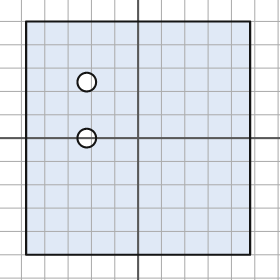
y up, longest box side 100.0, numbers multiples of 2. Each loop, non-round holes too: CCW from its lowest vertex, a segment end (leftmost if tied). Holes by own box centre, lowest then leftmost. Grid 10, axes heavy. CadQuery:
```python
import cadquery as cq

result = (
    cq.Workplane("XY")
    .moveTo(-48.0, -50.0)
    .lineTo(48.0, -50.0)
    .lineTo(48.0, 50.0)
    .lineTo(-48.0, 50.0)
    .close()
    .moveTo(-22.0, 0.0)
    .circle(4.0)
    .moveTo(-22.0, 24.0)
    .circle(4.0)
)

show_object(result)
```